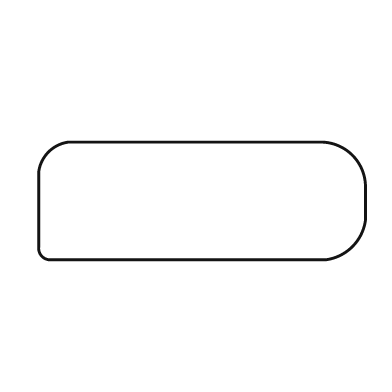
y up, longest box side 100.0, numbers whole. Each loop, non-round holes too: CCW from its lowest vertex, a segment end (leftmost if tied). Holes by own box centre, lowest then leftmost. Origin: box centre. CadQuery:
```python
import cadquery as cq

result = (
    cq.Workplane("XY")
    .moveTo(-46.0, -18.0)
    .lineTo(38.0, -18.0)
    .threePointArc((46.0, -14.0), (50.0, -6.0))
    .lineTo(50.0, 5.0)
    .threePointArc((46.0, 14.0), (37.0, 18.0))
    .lineTo(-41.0, 18.0)
    .threePointArc((-47.0, 15.0), (-50.0, 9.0))
    .lineTo(-50.0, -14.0)
    .threePointArc((-49.0, -17.0), (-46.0, -18.0))
    .close()
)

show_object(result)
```